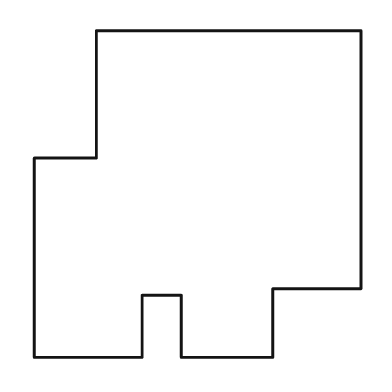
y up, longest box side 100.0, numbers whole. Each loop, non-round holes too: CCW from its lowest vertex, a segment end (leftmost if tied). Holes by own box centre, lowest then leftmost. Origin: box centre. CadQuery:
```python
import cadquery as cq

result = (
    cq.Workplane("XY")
    .moveTo(-50.0, -50.0)
    .lineTo(-17.0, -50.0)
    .lineTo(-17.0, -31.0)
    .lineTo(-5.0, -31.0)
    .lineTo(-5.0, -50.0)
    .lineTo(23.0, -50.0)
    .lineTo(23.0, -29.0)
    .lineTo(50.0, -29.0)
    .lineTo(50.0, 50.0)
    .lineTo(-31.0, 50.0)
    .lineTo(-31.0, 11.0)
    .lineTo(-50.0, 11.0)
    .close()
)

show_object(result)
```